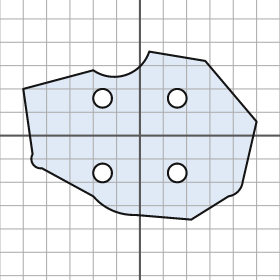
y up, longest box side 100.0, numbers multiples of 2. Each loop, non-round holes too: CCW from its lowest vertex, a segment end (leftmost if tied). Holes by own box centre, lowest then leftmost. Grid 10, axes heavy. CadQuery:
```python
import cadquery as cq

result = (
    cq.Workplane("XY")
    .moveTo(22.0, -36.0)
    .lineTo(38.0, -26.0)
    .threePointArc((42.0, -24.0), (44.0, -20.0))
    .lineTo(50.0, 6.0)
    .lineTo(28.0, 32.0)
    .lineTo(4.0, 36.0)
    .threePointArc((-6.0, 26.0), (-20.0, 28.0))
    .lineTo(-50.0, 20.0)
    .lineTo(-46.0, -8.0)
    .threePointArc((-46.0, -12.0), (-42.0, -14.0))
    .lineTo(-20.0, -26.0)
    .threePointArc((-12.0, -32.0), (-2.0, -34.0))
    .close()
    .moveTo(-16.0, -16.0)
    .circle(4.0)
    .moveTo(16.0, -16.0)
    .circle(4.0)
    .moveTo(-16.0, 16.0)
    .circle(4.0)
    .moveTo(16.0, 16.0)
    .circle(4.0)
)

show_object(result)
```